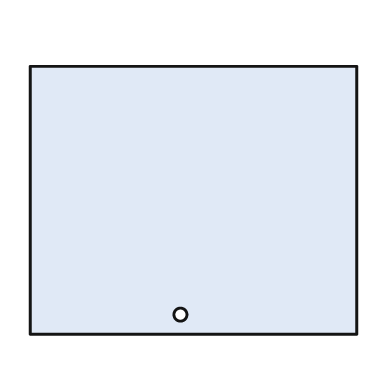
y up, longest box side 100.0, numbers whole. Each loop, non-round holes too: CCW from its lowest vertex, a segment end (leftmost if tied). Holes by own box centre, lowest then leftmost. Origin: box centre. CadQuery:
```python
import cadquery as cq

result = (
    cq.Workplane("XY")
    .moveTo(-50.0, -41.0)
    .lineTo(50.0, -41.0)
    .lineTo(50.0, 41.0)
    .lineTo(-50.0, 41.0)
    .close()
    .moveTo(-4.0, -35.0)
    .circle(2.0)
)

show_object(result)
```